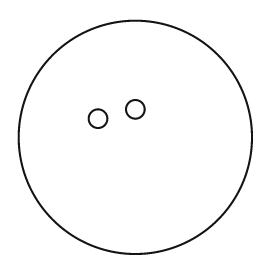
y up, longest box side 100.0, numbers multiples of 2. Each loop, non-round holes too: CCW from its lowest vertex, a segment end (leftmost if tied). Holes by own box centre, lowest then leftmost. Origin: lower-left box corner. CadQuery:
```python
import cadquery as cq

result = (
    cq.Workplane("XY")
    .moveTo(50.0, 50.0)
    .circle(50.0)
    .moveTo(34.0, 58.0)
    .circle(4.0)
    .moveTo(50.0, 62.0)
    .circle(4.0)
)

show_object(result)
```